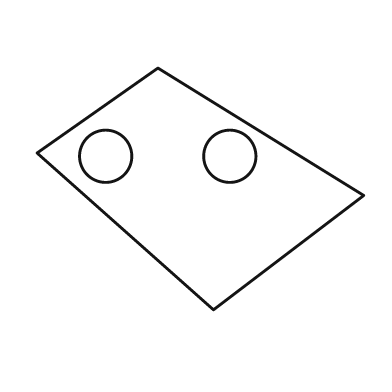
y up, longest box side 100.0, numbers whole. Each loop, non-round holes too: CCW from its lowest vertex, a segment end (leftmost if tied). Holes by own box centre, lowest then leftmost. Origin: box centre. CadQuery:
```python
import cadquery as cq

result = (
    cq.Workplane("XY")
    .moveTo(4.0, -37.0)
    .lineTo(50.0, -2.0)
    .lineTo(-13.0, 37.0)
    .lineTo(-50.0, 11.0)
    .close()
    .moveTo(-29.0, 10.0)
    .circle(8.0)
    .moveTo(9.0, 10.0)
    .circle(8.0)
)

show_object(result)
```